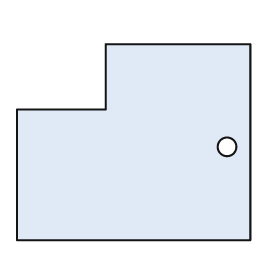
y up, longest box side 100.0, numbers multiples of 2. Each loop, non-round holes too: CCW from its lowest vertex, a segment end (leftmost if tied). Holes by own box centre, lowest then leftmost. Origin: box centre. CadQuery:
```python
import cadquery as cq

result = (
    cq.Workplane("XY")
    .moveTo(-50.0, -42.0)
    .lineTo(50.0, -42.0)
    .lineTo(50.0, 42.0)
    .lineTo(-12.0, 42.0)
    .lineTo(-12.0, 14.0)
    .lineTo(-50.0, 14.0)
    .close()
    .moveTo(40.0, -2.0)
    .circle(4.0)
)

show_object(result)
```